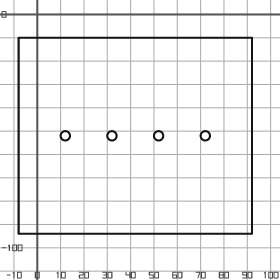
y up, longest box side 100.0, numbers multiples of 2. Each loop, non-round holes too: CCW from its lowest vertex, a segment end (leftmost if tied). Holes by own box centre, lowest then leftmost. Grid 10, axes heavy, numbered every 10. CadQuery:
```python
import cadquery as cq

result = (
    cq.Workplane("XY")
    .moveTo(-8.0, -94.0)
    .lineTo(92.0, -94.0)
    .lineTo(92.0, -10.0)
    .lineTo(-8.0, -10.0)
    .close()
    .moveTo(12.0, -52.0)
    .circle(2.0)
    .moveTo(32.0, -52.0)
    .circle(2.0)
    .moveTo(52.0, -52.0)
    .circle(2.0)
    .moveTo(72.0, -52.0)
    .circle(2.0)
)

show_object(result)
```